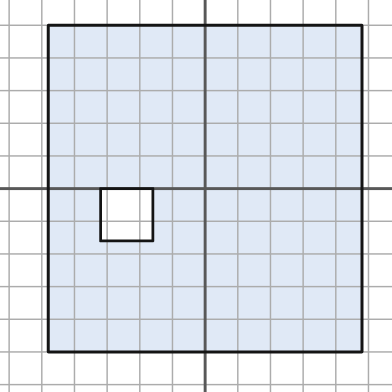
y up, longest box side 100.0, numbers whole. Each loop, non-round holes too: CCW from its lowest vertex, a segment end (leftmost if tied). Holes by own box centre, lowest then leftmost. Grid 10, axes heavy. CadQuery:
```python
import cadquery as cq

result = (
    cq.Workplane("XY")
    .moveTo(-48.0, -50.0)
    .lineTo(48.0, -50.0)
    .lineTo(48.0, 50.0)
    .lineTo(-48.0, 50.0)
    .close()
    .moveTo(-32.0, -16.0)
    .lineTo(-16.0, -16.0)
    .lineTo(-16.0, 0.0)
    .lineTo(-32.0, 0.0)
    .close()
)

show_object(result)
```